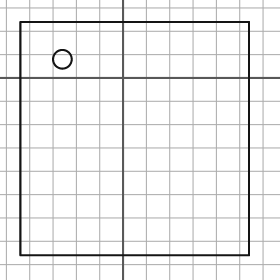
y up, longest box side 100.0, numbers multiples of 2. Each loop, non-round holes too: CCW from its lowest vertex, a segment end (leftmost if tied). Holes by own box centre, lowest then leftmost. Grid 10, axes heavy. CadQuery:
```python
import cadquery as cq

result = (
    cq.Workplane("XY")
    .moveTo(-44.0, -76.0)
    .lineTo(54.0, -76.0)
    .lineTo(54.0, 24.0)
    .lineTo(-44.0, 24.0)
    .close()
    .moveTo(-26.0, 8.0)
    .circle(4.0)
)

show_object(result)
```